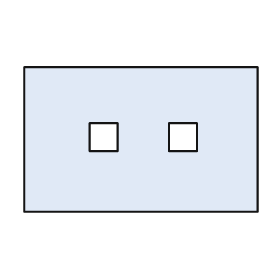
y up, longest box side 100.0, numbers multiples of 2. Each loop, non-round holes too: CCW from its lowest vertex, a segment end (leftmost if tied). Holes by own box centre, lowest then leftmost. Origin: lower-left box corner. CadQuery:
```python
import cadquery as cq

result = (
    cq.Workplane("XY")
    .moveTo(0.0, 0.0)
    .lineTo(100.0, 0.0)
    .lineTo(100.0, 62.0)
    .lineTo(0.0, 62.0)
    .close()
    .moveTo(28.0, 26.0)
    .lineTo(40.0, 26.0)
    .lineTo(40.0, 38.0)
    .lineTo(28.0, 38.0)
    .close()
    .moveTo(62.0, 26.0)
    .lineTo(74.0, 26.0)
    .lineTo(74.0, 38.0)
    .lineTo(62.0, 38.0)
    .close()
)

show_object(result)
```